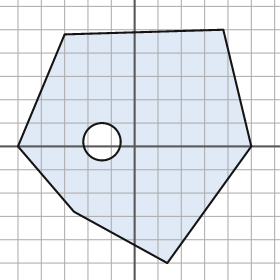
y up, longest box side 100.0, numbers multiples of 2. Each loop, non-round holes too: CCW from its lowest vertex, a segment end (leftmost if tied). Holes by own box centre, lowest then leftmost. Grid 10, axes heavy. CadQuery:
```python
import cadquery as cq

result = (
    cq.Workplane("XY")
    .moveTo(14.0, -50.0)
    .lineTo(50.0, 0.0)
    .lineTo(38.0, 50.0)
    .lineTo(-30.0, 48.0)
    .lineTo(-50.0, 0.0)
    .lineTo(-26.0, -28.0)
    .close()
    .moveTo(-14.0, 2.0)
    .circle(8.0)
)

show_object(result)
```